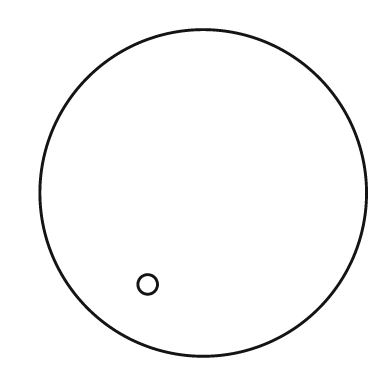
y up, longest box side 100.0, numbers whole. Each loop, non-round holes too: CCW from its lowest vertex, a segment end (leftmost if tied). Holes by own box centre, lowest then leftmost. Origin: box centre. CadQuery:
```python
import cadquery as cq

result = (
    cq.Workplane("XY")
    .moveTo(0.0, 0.0)
    .circle(50.0)
    .moveTo(-17.0, -28.0)
    .circle(3.0)
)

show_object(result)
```